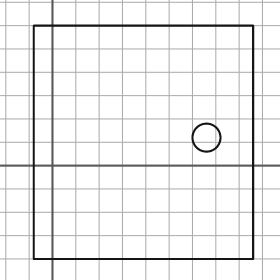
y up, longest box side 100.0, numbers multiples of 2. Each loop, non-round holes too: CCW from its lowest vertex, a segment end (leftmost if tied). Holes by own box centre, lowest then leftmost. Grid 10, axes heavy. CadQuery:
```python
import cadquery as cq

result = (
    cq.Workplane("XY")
    .moveTo(-8.0, -40.0)
    .lineTo(86.0, -40.0)
    .lineTo(86.0, 60.0)
    .lineTo(-8.0, 60.0)
    .close()
    .moveTo(66.0, 12.0)
    .circle(6.0)
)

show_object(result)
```